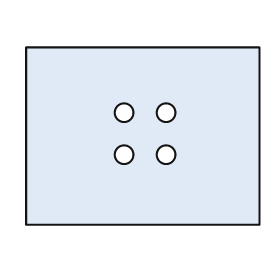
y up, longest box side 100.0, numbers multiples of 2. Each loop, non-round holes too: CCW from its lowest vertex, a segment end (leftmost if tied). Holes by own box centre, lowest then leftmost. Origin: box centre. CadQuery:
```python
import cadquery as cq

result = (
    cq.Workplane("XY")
    .moveTo(-50.0, -38.0)
    .lineTo(50.0, -38.0)
    .lineTo(50.0, 38.0)
    .lineTo(-50.0, 38.0)
    .close()
    .moveTo(-8.0, -8.0)
    .circle(4.0)
    .moveTo(10.0, -8.0)
    .circle(4.0)
    .moveTo(-8.0, 10.0)
    .circle(4.0)
    .moveTo(10.0, 10.0)
    .circle(4.0)
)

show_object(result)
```